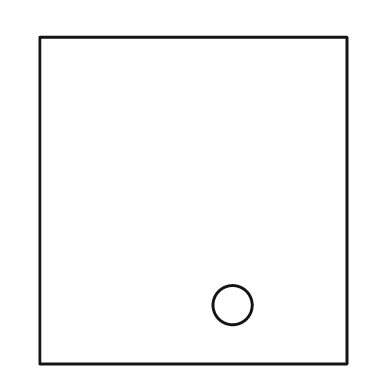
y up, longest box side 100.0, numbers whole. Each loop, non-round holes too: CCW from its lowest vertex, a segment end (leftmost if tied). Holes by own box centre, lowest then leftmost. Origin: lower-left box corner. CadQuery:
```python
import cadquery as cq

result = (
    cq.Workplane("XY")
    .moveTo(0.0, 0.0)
    .lineTo(94.0, 0.0)
    .lineTo(94.0, 100.0)
    .lineTo(0.0, 100.0)
    .close()
    .moveTo(59.0, 18.0)
    .circle(6.0)
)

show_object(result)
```